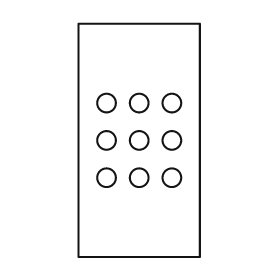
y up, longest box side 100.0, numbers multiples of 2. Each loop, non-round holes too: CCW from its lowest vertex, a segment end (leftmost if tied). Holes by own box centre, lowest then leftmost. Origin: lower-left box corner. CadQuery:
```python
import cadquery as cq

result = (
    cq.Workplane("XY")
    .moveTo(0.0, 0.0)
    .lineTo(52.0, 0.0)
    .lineTo(52.0, 100.0)
    .lineTo(0.0, 100.0)
    .close()
    .moveTo(12.0, 34.0)
    .circle(4.0)
    .moveTo(26.0, 34.0)
    .circle(4.0)
    .moveTo(40.0, 34.0)
    .circle(4.0)
    .moveTo(12.0, 50.0)
    .circle(4.0)
    .moveTo(26.0, 50.0)
    .circle(4.0)
    .moveTo(40.0, 50.0)
    .circle(4.0)
    .moveTo(12.0, 66.0)
    .circle(4.0)
    .moveTo(26.0, 66.0)
    .circle(4.0)
    .moveTo(40.0, 66.0)
    .circle(4.0)
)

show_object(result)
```